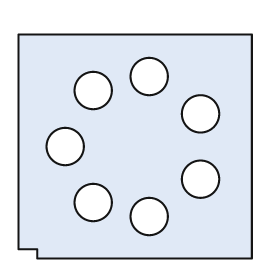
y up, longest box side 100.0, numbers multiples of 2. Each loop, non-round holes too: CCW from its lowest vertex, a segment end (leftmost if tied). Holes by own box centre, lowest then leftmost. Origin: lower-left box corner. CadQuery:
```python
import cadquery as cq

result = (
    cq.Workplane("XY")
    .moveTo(8.0, 0.0)
    .lineTo(100.0, 0.0)
    .lineTo(100.0, 96.0)
    .lineTo(0.0, 96.0)
    .lineTo(0.0, 4.0)
    .lineTo(8.0, 4.0)
    .close()
    .moveTo(56.0, 18.0)
    .circle(8.0)
    .moveTo(32.0, 24.0)
    .circle(8.0)
    .moveTo(78.0, 34.0)
    .circle(8.0)
    .moveTo(20.0, 48.0)
    .circle(8.0)
    .moveTo(78.0, 62.0)
    .circle(8.0)
    .moveTo(32.0, 72.0)
    .circle(8.0)
    .moveTo(56.0, 78.0)
    .circle(8.0)
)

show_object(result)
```